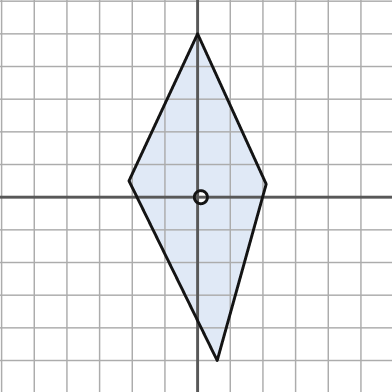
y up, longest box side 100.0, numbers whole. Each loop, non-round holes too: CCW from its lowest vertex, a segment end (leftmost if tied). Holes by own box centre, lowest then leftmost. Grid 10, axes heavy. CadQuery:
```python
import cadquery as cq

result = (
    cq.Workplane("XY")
    .moveTo(6.0, -50.0)
    .lineTo(21.0, 4.0)
    .lineTo(0.0, 50.0)
    .lineTo(-21.0, 5.0)
    .close()
    .moveTo(1.0, 0.0)
    .circle(2.0)
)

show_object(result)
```